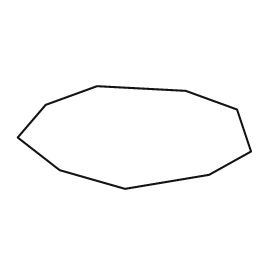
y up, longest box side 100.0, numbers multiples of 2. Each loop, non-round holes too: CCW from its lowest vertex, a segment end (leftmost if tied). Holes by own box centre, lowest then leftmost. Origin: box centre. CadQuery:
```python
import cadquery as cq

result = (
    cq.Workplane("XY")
    .moveTo(-4.0, -22.0)
    .lineTo(32.0, -16.0)
    .lineTo(50.0, -6.0)
    .lineTo(44.0, 12.0)
    .lineTo(22.0, 20.0)
    .lineTo(-16.0, 22.0)
    .lineTo(-38.0, 14.0)
    .lineTo(-50.0, 0.0)
    .lineTo(-32.0, -14.0)
    .close()
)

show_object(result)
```